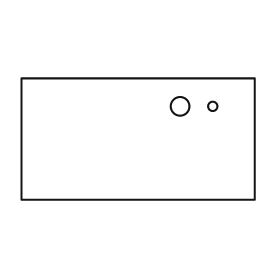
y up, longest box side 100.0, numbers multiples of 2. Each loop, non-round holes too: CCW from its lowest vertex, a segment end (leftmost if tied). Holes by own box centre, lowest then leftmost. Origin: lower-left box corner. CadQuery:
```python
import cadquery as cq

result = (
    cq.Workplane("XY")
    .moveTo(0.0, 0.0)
    .lineTo(100.0, 0.0)
    .lineTo(100.0, 52.0)
    .lineTo(0.0, 52.0)
    .close()
    .moveTo(68.0, 40.0)
    .circle(4.0)
    .moveTo(82.0, 40.0)
    .circle(2.0)
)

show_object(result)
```